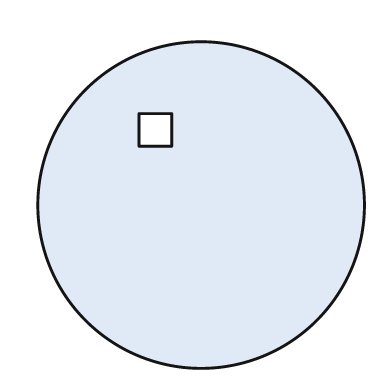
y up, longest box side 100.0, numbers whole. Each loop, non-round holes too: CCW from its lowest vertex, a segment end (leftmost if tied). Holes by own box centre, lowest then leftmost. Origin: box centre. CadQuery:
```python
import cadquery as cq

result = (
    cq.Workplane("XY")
    .moveTo(0.0, 0.0)
    .circle(50.0)
    .moveTo(-19.0, 18.0)
    .lineTo(-9.0, 18.0)
    .lineTo(-9.0, 28.0)
    .lineTo(-19.0, 28.0)
    .close()
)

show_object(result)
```